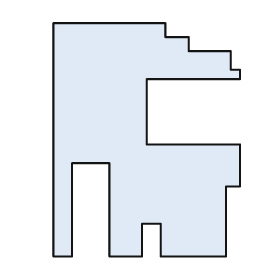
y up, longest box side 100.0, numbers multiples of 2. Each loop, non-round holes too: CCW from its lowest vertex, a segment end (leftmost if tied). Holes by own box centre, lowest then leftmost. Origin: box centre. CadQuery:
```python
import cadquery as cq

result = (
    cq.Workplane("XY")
    .moveTo(-40.0, -50.0)
    .lineTo(-32.0, -50.0)
    .lineTo(-32.0, -10.0)
    .lineTo(-16.0, -10.0)
    .lineTo(-16.0, -50.0)
    .lineTo(-2.0, -50.0)
    .lineTo(-2.0, -36.0)
    .lineTo(6.0, -36.0)
    .lineTo(6.0, -50.0)
    .lineTo(34.0, -50.0)
    .lineTo(34.0, -20.0)
    .lineTo(40.0, -20.0)
    .lineTo(40.0, -2.0)
    .lineTo(0.0, -2.0)
    .lineTo(0.0, 26.0)
    .lineTo(40.0, 26.0)
    .lineTo(40.0, 30.0)
    .lineTo(36.0, 30.0)
    .lineTo(36.0, 38.0)
    .lineTo(18.0, 38.0)
    .lineTo(18.0, 44.0)
    .lineTo(8.0, 44.0)
    .lineTo(8.0, 50.0)
    .lineTo(-40.0, 50.0)
    .close()
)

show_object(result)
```